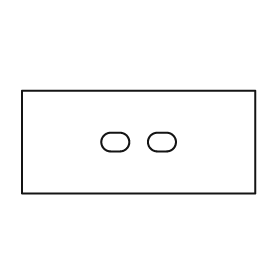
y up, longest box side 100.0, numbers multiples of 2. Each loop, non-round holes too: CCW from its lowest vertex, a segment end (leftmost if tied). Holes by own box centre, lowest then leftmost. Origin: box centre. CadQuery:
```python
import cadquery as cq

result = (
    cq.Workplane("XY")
    .moveTo(-50.0, -22.0)
    .lineTo(50.0, -22.0)
    .lineTo(50.0, 22.0)
    .lineTo(-50.0, 22.0)
    .close()
    .moveTo(-12.0, -4.0)
    .lineTo(-8.0, -4.0)
    .threePointArc((-4.0, 0.0), (-8.0, 4.0))
    .lineTo(-12.0, 4.0)
    .threePointArc((-16.0, 0.0), (-12.0, -4.0))
    .close()
    .moveTo(8.0, -4.0)
    .lineTo(12.0, -4.0)
    .threePointArc((16.0, 0.0), (12.0, 4.0))
    .lineTo(8.0, 4.0)
    .threePointArc((4.0, 0.0), (8.0, -4.0))
    .close()
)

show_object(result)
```